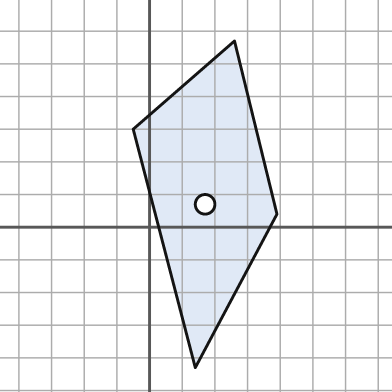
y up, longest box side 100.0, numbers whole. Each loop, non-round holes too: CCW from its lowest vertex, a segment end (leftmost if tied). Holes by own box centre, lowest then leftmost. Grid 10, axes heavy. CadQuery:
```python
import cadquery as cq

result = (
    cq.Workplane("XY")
    .moveTo(14.0, -43.0)
    .lineTo(39.0, 4.0)
    .lineTo(26.0, 57.0)
    .lineTo(-5.0, 30.0)
    .close()
    .moveTo(17.0, 7.0)
    .circle(3.0)
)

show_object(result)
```